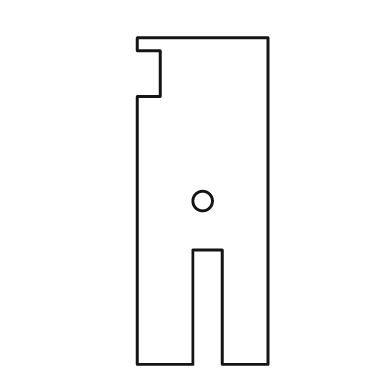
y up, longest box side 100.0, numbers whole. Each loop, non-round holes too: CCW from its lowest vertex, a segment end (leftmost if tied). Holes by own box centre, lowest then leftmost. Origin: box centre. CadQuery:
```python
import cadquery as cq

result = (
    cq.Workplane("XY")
    .moveTo(-20.0, -50.0)
    .lineTo(-3.0, -50.0)
    .lineTo(-3.0, -15.0)
    .lineTo(6.0, -15.0)
    .lineTo(6.0, -50.0)
    .lineTo(20.0, -50.0)
    .lineTo(20.0, 50.0)
    .lineTo(-20.0, 50.0)
    .lineTo(-20.0, 46.0)
    .lineTo(-13.0, 46.0)
    .lineTo(-13.0, 32.0)
    .lineTo(-20.0, 32.0)
    .close()
    .moveTo(0.0, 0.0)
    .circle(3.0)
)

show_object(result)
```